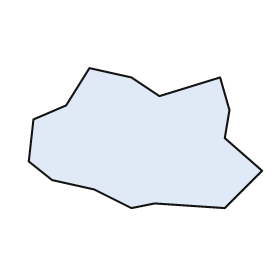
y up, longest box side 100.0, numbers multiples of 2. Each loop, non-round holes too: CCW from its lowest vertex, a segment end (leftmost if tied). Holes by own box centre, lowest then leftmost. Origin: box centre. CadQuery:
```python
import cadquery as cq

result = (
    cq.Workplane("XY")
    .moveTo(-6.0, -30.0)
    .lineTo(4.0, -28.0)
    .lineTo(34.0, -30.0)
    .lineTo(50.0, -14.0)
    .lineTo(34.0, 0.0)
    .lineTo(36.0, 12.0)
    .lineTo(32.0, 26.0)
    .lineTo(6.0, 18.0)
    .lineTo(-6.0, 26.0)
    .lineTo(-24.0, 30.0)
    .lineTo(-34.0, 14.0)
    .lineTo(-48.0, 8.0)
    .lineTo(-50.0, -10.0)
    .lineTo(-40.0, -18.0)
    .lineTo(-22.0, -22.0)
    .close()
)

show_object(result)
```